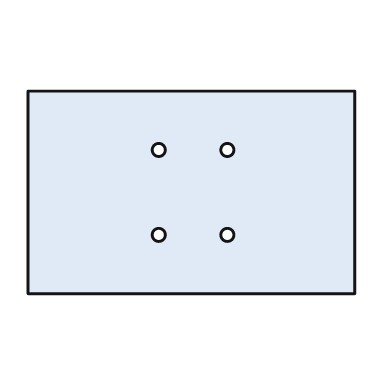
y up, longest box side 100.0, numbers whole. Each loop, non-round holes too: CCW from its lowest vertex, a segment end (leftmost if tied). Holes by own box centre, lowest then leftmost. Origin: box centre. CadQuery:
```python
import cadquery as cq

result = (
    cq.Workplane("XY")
    .moveTo(-50.0, -31.0)
    .lineTo(50.0, -31.0)
    .lineTo(50.0, 31.0)
    .lineTo(-50.0, 31.0)
    .close()
    .moveTo(-10.0, -13.0)
    .circle(2.0)
    .moveTo(11.0, -13.0)
    .circle(2.0)
    .moveTo(-10.0, 13.0)
    .circle(2.0)
    .moveTo(11.0, 13.0)
    .circle(2.0)
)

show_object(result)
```